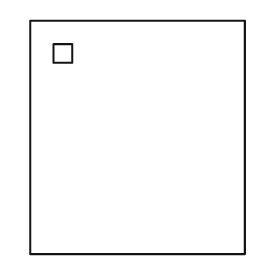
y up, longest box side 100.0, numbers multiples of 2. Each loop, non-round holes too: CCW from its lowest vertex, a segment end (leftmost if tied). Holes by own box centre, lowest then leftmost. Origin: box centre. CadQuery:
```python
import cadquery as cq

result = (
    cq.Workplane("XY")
    .moveTo(-46.0, -50.0)
    .lineTo(46.0, -50.0)
    .lineTo(46.0, 50.0)
    .lineTo(-46.0, 50.0)
    .close()
    .moveTo(-36.0, 32.0)
    .lineTo(-28.0, 32.0)
    .lineTo(-28.0, 40.0)
    .lineTo(-36.0, 40.0)
    .close()
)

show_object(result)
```